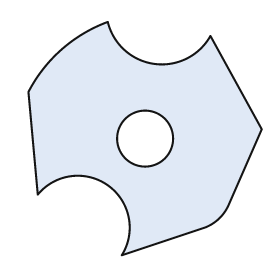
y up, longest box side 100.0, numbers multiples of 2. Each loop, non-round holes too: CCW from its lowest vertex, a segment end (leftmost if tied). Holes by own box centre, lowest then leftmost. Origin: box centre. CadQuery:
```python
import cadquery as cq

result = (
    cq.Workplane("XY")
    .moveTo(-10.0, -50.0)
    .lineTo(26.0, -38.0)
    .threePointArc((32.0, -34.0), (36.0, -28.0))
    .lineTo(50.0, 4.0)
    .lineTo(28.0, 44.0)
    .threePointArc((4.0, 32.0), (-16.0, 50.0))
    .threePointArc((-36.0, 38.0), (-50.0, 20.0))
    .lineTo(-46.0, -24.0)
    .threePointArc((-16.0, -20.0), (-10.0, -50.0))
    .close()
    .moveTo(0.0, 0.0)
    .circle(12.0)
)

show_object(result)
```